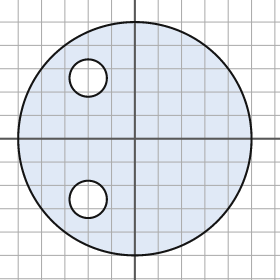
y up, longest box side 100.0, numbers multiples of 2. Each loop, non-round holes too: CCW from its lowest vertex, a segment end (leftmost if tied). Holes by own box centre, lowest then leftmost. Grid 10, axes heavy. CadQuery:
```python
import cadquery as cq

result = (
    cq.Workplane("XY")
    .moveTo(0.0, 0.0)
    .circle(50.0)
    .moveTo(-20.0, -26.0)
    .circle(8.0)
    .moveTo(-20.0, 26.0)
    .circle(8.0)
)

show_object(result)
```